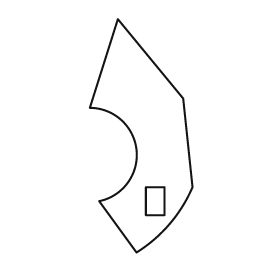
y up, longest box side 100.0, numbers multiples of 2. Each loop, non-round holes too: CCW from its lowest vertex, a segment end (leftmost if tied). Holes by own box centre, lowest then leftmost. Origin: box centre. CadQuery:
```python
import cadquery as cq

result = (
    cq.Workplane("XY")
    .moveTo(-2.0, -50.0)
    .threePointArc((12.0, -38.0), (22.0, -22.0))
    .lineTo(18.0, 16.0)
    .lineTo(-10.0, 50.0)
    .lineTo(-22.0, 12.0)
    .threePointArc((-2.0, -6.0), (-18.0, -28.0))
    .close()
    .moveTo(2.0, -34.0)
    .lineTo(10.0, -34.0)
    .lineTo(10.0, -22.0)
    .lineTo(2.0, -22.0)
    .close()
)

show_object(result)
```